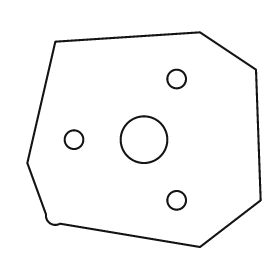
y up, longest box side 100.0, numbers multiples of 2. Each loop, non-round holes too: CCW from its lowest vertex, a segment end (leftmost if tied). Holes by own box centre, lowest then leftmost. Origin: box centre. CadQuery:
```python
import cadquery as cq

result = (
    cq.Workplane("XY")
    .moveTo(24.0, -46.0)
    .lineTo(50.0, -26.0)
    .lineTo(48.0, 30.0)
    .lineTo(24.0, 46.0)
    .lineTo(-38.0, 42.0)
    .lineTo(-50.0, -10.0)
    .lineTo(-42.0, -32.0)
    .threePointArc((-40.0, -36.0), (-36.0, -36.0))
    .close()
    .moveTo(14.0, -26.0)
    .circle(4.0)
    .moveTo(-30.0, 0.0)
    .circle(4.0)
    .moveTo(0.0, 0.0)
    .circle(10.0)
    .moveTo(14.0, 26.0)
    .circle(4.0)
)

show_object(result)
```